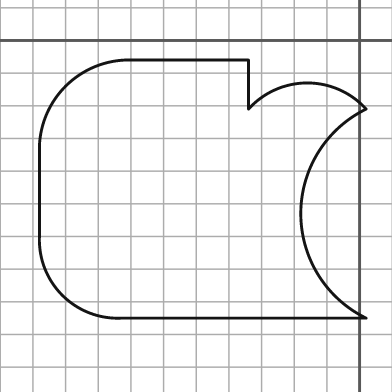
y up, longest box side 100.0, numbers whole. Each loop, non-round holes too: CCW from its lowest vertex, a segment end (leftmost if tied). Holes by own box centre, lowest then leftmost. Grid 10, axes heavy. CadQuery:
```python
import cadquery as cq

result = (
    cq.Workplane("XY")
    .moveTo(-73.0, -85.0)
    .lineTo(2.0, -85.0)
    .threePointArc((-18.0, -53.0), (2.0, -21.0))
    .threePointArc((-16.0, -13.0), (-34.0, -21.0))
    .lineTo(-34.0, -6.0)
    .lineTo(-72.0, -6.0)
    .threePointArc((-90.0, -14.0), (-98.0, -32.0))
    .lineTo(-98.0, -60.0)
    .threePointArc((-91.0, -78.0), (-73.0, -85.0))
    .close()
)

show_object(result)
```